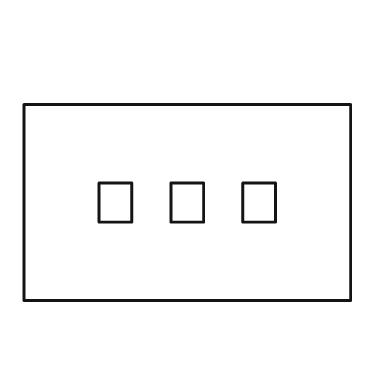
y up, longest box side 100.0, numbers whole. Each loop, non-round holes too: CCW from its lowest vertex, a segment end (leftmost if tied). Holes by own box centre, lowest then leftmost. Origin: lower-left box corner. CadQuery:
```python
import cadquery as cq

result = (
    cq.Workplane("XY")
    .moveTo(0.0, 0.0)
    .lineTo(100.0, 0.0)
    .lineTo(100.0, 60.0)
    .lineTo(0.0, 60.0)
    .close()
    .moveTo(23.0, 24.0)
    .lineTo(33.0, 24.0)
    .lineTo(33.0, 36.0)
    .lineTo(23.0, 36.0)
    .close()
    .moveTo(45.0, 24.0)
    .lineTo(55.0, 24.0)
    .lineTo(55.0, 36.0)
    .lineTo(45.0, 36.0)
    .close()
    .moveTo(67.0, 24.0)
    .lineTo(77.0, 24.0)
    .lineTo(77.0, 36.0)
    .lineTo(67.0, 36.0)
    .close()
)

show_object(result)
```